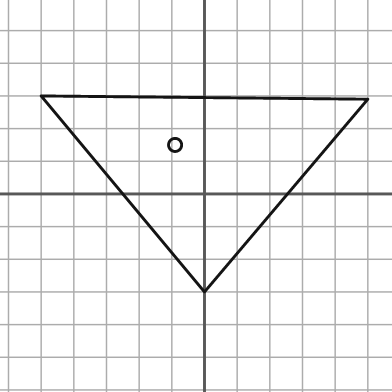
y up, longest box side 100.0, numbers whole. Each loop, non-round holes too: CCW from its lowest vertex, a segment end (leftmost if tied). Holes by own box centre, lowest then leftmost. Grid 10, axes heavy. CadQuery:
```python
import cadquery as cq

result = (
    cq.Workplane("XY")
    .moveTo(0.0, -30.0)
    .lineTo(50.0, 29.0)
    .lineTo(-50.0, 30.0)
    .close()
    .moveTo(-9.0, 15.0)
    .circle(2.0)
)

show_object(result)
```